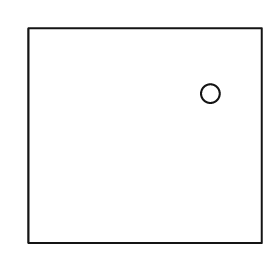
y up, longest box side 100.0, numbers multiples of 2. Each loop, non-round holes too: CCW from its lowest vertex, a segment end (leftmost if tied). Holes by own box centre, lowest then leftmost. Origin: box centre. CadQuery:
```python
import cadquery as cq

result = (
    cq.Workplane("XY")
    .moveTo(-50.0, -46.0)
    .lineTo(50.0, -46.0)
    .lineTo(50.0, 46.0)
    .lineTo(-50.0, 46.0)
    .close()
    .moveTo(28.0, 18.0)
    .circle(4.0)
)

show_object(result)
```